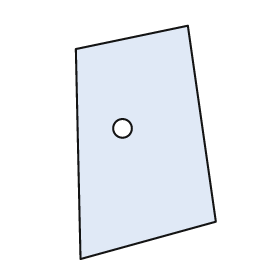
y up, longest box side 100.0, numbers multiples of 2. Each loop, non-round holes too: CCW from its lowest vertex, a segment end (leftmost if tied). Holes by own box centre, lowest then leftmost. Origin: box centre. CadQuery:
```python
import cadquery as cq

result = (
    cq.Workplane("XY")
    .moveTo(-28.0, -50.0)
    .lineTo(30.0, -34.0)
    .lineTo(18.0, 50.0)
    .lineTo(-30.0, 40.0)
    .close()
    .moveTo(-10.0, 6.0)
    .circle(4.0)
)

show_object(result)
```